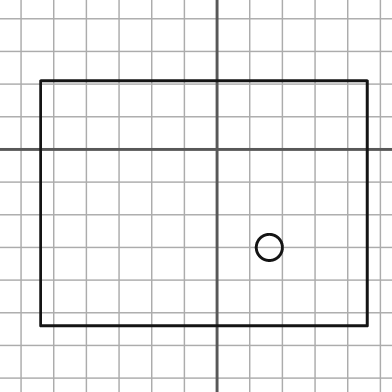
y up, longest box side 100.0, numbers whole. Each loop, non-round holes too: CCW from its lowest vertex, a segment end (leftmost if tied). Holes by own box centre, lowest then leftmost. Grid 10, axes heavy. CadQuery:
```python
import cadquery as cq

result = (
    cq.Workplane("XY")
    .moveTo(-54.0, -54.0)
    .lineTo(46.0, -54.0)
    .lineTo(46.0, 21.0)
    .lineTo(-54.0, 21.0)
    .close()
    .moveTo(16.0, -30.0)
    .circle(4.0)
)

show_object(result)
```